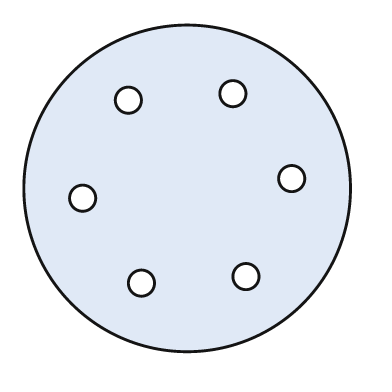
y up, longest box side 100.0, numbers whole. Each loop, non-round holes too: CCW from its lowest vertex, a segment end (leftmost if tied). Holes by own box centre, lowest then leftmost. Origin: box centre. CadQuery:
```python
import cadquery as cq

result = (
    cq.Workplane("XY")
    .moveTo(0.0, 0.0)
    .circle(50.0)
    .moveTo(-14.0, -29.0)
    .circle(4.0)
    .moveTo(18.0, -27.0)
    .circle(4.0)
    .moveTo(-32.0, -3.0)
    .circle(4.0)
    .moveTo(32.0, 3.0)
    .circle(4.0)
    .moveTo(-18.0, 27.0)
    .circle(4.0)
    .moveTo(14.0, 29.0)
    .circle(4.0)
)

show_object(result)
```